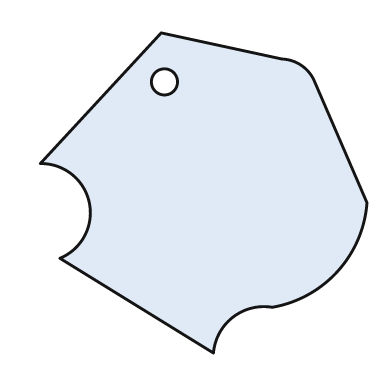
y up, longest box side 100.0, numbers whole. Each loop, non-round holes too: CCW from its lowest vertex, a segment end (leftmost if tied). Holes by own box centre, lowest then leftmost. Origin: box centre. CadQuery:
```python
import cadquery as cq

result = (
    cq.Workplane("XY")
    .moveTo(3.0, -49.0)
    .threePointArc((9.0, -38.0), (21.0, -35.0))
    .threePointArc((41.0, -24.0), (50.0, -3.0))
    .lineTo(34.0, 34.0)
    .threePointArc((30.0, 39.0), (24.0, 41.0))
    .lineTo(-13.0, 49.0)
    .lineTo(-50.0, 9.0)
    .threePointArc((-35.0, -3.0), (-44.0, -20.0))
    .close()
    .moveTo(-12.0, 34.0)
    .circle(4.0)
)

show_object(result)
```